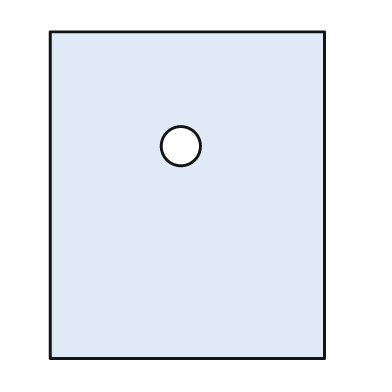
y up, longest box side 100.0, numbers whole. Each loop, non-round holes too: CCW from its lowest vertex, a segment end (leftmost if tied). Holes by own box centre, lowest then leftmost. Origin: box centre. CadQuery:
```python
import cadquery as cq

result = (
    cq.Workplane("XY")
    .moveTo(-42.0, -50.0)
    .lineTo(42.0, -50.0)
    .lineTo(42.0, 50.0)
    .lineTo(-42.0, 50.0)
    .close()
    .moveTo(-2.0, 15.0)
    .circle(6.0)
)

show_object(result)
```